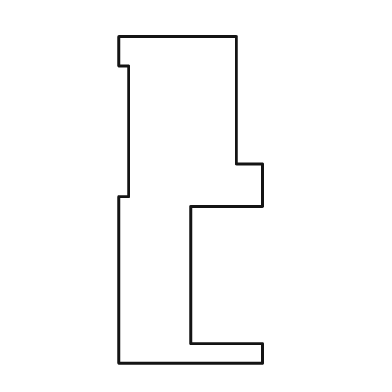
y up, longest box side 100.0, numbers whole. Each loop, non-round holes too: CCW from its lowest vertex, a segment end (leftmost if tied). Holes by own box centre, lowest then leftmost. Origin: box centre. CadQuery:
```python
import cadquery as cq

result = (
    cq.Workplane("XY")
    .moveTo(-22.0, -50.0)
    .lineTo(22.0, -50.0)
    .lineTo(22.0, -44.0)
    .lineTo(0.0, -44.0)
    .lineTo(0.0, -2.0)
    .lineTo(22.0, -2.0)
    .lineTo(22.0, 11.0)
    .lineTo(14.0, 11.0)
    .lineTo(14.0, 50.0)
    .lineTo(-22.0, 50.0)
    .lineTo(-22.0, 41.0)
    .lineTo(-19.0, 41.0)
    .lineTo(-19.0, 1.0)
    .lineTo(-22.0, 1.0)
    .close()
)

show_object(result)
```